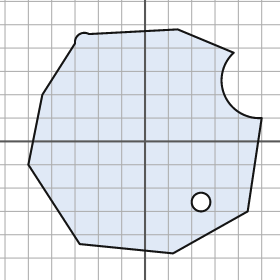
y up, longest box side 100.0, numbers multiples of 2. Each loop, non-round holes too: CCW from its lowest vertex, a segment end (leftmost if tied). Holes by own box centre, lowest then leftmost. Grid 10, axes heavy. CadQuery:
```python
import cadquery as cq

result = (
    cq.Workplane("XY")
    .moveTo(12.0, -48.0)
    .lineTo(44.0, -30.0)
    .lineTo(50.0, 10.0)
    .threePointArc((34.0, 20.0), (38.0, 38.0))
    .lineTo(14.0, 48.0)
    .lineTo(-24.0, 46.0)
    .threePointArc((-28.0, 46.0), (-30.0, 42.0))
    .lineTo(-44.0, 20.0)
    .lineTo(-50.0, -10.0)
    .lineTo(-28.0, -44.0)
    .close()
    .moveTo(24.0, -26.0)
    .circle(4.0)
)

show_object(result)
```